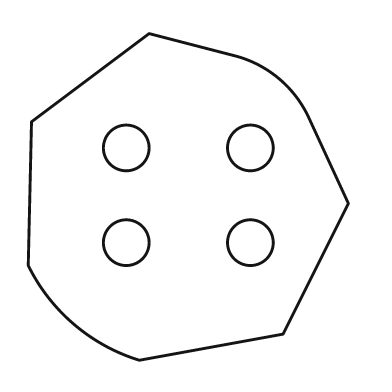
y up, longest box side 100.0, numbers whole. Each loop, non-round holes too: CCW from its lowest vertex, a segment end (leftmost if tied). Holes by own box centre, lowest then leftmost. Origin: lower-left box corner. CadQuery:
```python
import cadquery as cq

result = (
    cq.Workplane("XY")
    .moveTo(34.0, 0.0)
    .lineTo(78.0, 8.0)
    .lineTo(98.0, 48.0)
    .lineTo(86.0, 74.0)
    .threePointArc((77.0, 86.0), (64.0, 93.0))
    .lineTo(37.0, 100.0)
    .lineTo(1.0, 73.0)
    .lineTo(0.0, 29.0)
    .threePointArc((14.0, 11.0), (34.0, 0.0))
    .close()
    .moveTo(30.0, 36.0)
    .circle(7.0)
    .moveTo(68.0, 36.0)
    .circle(7.0)
    .moveTo(30.0, 65.0)
    .circle(7.0)
    .moveTo(68.0, 65.0)
    .circle(7.0)
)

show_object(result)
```